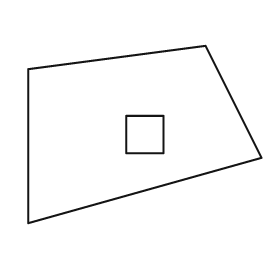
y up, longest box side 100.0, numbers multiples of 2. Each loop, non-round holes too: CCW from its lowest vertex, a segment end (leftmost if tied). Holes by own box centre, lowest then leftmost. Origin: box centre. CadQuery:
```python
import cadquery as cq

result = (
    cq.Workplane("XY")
    .moveTo(-50.0, -38.0)
    .lineTo(50.0, -10.0)
    .lineTo(26.0, 38.0)
    .lineTo(-50.0, 28.0)
    .close()
    .moveTo(-8.0, -8.0)
    .lineTo(8.0, -8.0)
    .lineTo(8.0, 8.0)
    .lineTo(-8.0, 8.0)
    .close()
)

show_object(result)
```